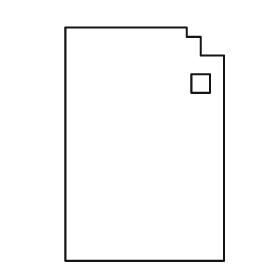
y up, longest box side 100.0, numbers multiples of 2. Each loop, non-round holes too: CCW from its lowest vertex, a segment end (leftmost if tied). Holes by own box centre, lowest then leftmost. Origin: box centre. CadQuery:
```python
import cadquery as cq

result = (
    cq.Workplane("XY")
    .moveTo(-34.0, -50.0)
    .lineTo(34.0, -50.0)
    .lineTo(34.0, 38.0)
    .lineTo(24.0, 38.0)
    .lineTo(24.0, 46.0)
    .lineTo(18.0, 46.0)
    .lineTo(18.0, 50.0)
    .lineTo(-34.0, 50.0)
    .close()
    .moveTo(20.0, 22.0)
    .lineTo(28.0, 22.0)
    .lineTo(28.0, 30.0)
    .lineTo(20.0, 30.0)
    .close()
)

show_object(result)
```